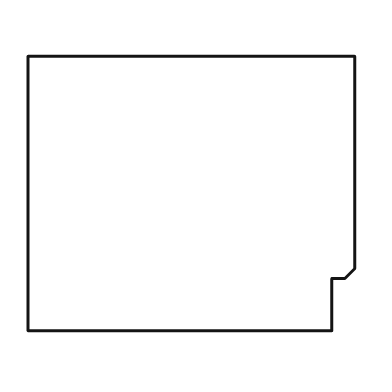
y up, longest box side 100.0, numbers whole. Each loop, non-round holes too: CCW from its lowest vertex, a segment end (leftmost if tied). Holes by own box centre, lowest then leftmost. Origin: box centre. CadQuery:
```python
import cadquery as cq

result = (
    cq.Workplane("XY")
    .moveTo(-50.0, -42.0)
    .lineTo(43.0, -42.0)
    .lineTo(43.0, -26.0)
    .lineTo(47.0, -26.0)
    .lineTo(50.0, -23.0)
    .lineTo(50.0, 42.0)
    .lineTo(-50.0, 42.0)
    .close()
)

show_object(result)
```